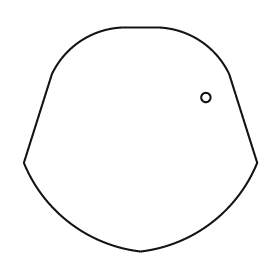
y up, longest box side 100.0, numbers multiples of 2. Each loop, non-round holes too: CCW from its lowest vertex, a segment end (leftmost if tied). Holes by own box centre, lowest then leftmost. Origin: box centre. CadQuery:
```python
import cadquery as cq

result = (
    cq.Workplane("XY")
    .moveTo(0.0, -48.0)
    .threePointArc((30.0, -36.0), (50.0, -10.0))
    .lineTo(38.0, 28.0)
    .threePointArc((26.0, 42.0), (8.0, 48.0))
    .lineTo(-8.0, 48.0)
    .threePointArc((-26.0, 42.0), (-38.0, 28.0))
    .lineTo(-50.0, -10.0)
    .threePointArc((-30.0, -36.0), (0.0, -48.0))
    .close()
    .moveTo(28.0, 18.0)
    .circle(2.0)
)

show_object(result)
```